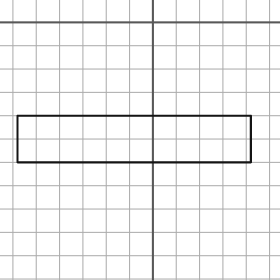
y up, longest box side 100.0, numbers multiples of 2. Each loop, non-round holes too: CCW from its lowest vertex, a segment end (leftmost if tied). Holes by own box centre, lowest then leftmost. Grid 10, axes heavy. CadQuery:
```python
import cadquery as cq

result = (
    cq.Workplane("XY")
    .moveTo(-58.0, -60.0)
    .lineTo(42.0, -60.0)
    .lineTo(42.0, -40.0)
    .lineTo(-58.0, -40.0)
    .close()
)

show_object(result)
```